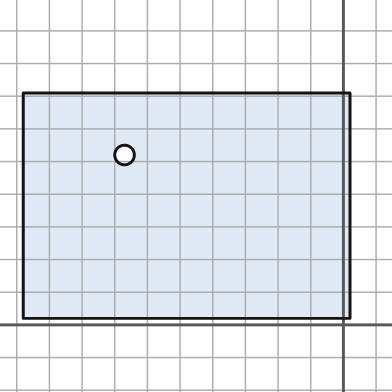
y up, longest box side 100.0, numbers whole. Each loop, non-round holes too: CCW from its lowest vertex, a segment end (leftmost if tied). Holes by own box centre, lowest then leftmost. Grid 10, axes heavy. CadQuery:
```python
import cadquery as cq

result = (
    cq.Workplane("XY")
    .moveTo(-98.0, 2.0)
    .lineTo(2.0, 2.0)
    .lineTo(2.0, 71.0)
    .lineTo(-98.0, 71.0)
    .close()
    .moveTo(-67.0, 52.0)
    .circle(3.0)
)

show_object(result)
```